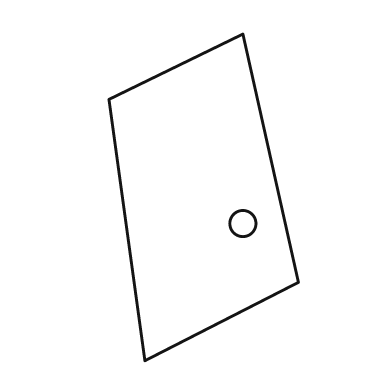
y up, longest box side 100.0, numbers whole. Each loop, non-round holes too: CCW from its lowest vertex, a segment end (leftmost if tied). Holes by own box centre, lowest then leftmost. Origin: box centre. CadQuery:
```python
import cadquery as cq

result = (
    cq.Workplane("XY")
    .moveTo(-18.0, -50.0)
    .lineTo(29.0, -26.0)
    .lineTo(12.0, 50.0)
    .lineTo(-29.0, 30.0)
    .close()
    .moveTo(12.0, -8.0)
    .circle(4.0)
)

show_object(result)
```